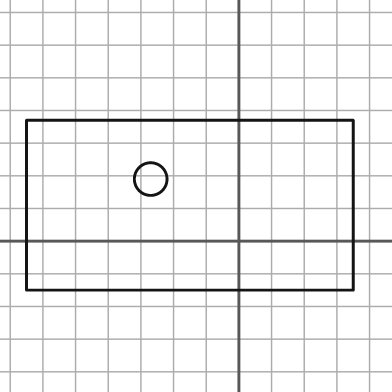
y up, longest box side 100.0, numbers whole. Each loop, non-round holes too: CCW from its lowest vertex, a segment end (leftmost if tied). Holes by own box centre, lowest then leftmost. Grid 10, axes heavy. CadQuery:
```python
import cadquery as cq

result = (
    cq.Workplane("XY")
    .moveTo(-65.0, -15.0)
    .lineTo(35.0, -15.0)
    .lineTo(35.0, 37.0)
    .lineTo(-65.0, 37.0)
    .close()
    .moveTo(-27.0, 19.0)
    .circle(5.0)
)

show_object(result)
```